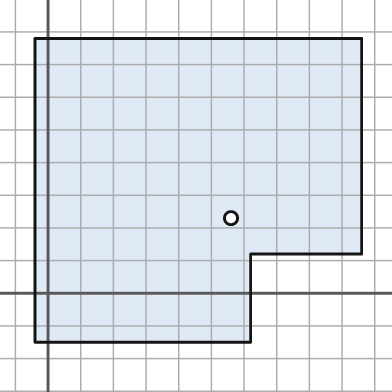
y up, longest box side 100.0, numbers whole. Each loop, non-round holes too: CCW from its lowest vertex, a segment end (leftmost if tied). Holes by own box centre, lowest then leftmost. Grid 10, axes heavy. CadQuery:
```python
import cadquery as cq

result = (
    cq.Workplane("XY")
    .moveTo(-4.0, -15.0)
    .lineTo(62.0, -15.0)
    .lineTo(62.0, 12.0)
    .lineTo(96.0, 12.0)
    .lineTo(96.0, 78.0)
    .lineTo(-4.0, 78.0)
    .close()
    .moveTo(56.0, 23.0)
    .circle(2.0)
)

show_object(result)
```